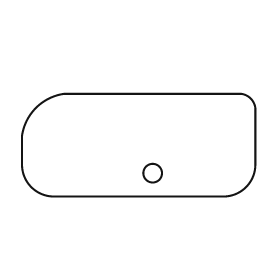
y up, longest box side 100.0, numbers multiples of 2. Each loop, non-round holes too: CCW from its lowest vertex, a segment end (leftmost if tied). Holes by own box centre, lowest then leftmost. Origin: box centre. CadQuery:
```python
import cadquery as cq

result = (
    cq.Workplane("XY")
    .moveTo(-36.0, -22.0)
    .lineTo(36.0, -22.0)
    .threePointArc((46.0, -18.0), (50.0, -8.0))
    .lineTo(50.0, 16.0)
    .threePointArc((48.0, 20.0), (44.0, 22.0))
    .lineTo(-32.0, 22.0)
    .threePointArc((-44.0, 16.0), (-50.0, 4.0))
    .lineTo(-50.0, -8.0)
    .threePointArc((-46.0, -18.0), (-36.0, -22.0))
    .close()
    .moveTo(6.0, -12.0)
    .circle(4.0)
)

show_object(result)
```